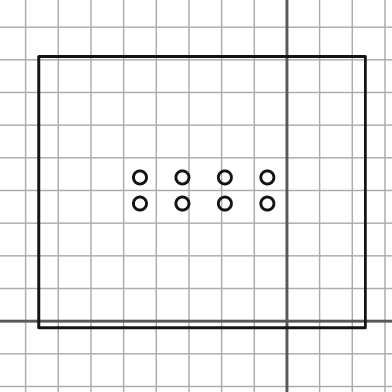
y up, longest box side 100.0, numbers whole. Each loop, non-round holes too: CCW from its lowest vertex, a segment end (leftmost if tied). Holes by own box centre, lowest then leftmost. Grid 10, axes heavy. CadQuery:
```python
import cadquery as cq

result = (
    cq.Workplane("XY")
    .moveTo(-76.0, -2.0)
    .lineTo(24.0, -2.0)
    .lineTo(24.0, 81.0)
    .lineTo(-76.0, 81.0)
    .close()
    .moveTo(-45.0, 36.0)
    .circle(2.0)
    .moveTo(-32.0, 36.0)
    .circle(2.0)
    .moveTo(-19.0, 36.0)
    .circle(2.0)
    .moveTo(-6.0, 36.0)
    .circle(2.0)
    .moveTo(-45.0, 44.0)
    .circle(2.0)
    .moveTo(-32.0, 44.0)
    .circle(2.0)
    .moveTo(-19.0, 44.0)
    .circle(2.0)
    .moveTo(-6.0, 44.0)
    .circle(2.0)
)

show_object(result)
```